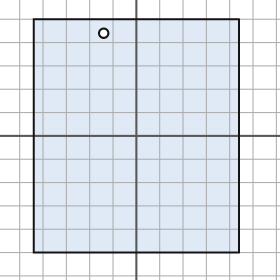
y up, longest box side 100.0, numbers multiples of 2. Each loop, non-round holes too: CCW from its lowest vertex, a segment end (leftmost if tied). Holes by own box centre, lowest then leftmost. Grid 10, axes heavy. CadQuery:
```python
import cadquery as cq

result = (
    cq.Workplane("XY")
    .moveTo(-44.0, -50.0)
    .lineTo(44.0, -50.0)
    .lineTo(44.0, 50.0)
    .lineTo(-44.0, 50.0)
    .close()
    .moveTo(-14.0, 44.0)
    .circle(2.0)
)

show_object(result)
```